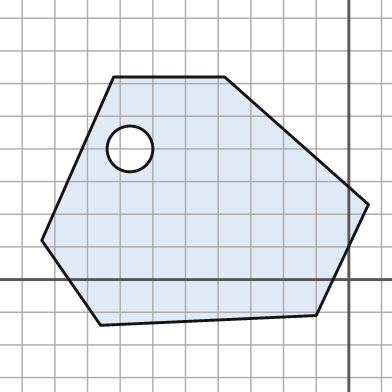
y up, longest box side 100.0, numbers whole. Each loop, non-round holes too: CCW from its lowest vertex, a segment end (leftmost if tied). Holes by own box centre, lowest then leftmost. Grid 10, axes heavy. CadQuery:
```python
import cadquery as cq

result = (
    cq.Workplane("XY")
    .moveTo(-76.0, -14.0)
    .lineTo(-10.0, -11.0)
    .lineTo(6.0, 23.0)
    .lineTo(-38.0, 62.0)
    .lineTo(-72.0, 62.0)
    .lineTo(-94.0, 12.0)
    .close()
    .moveTo(-67.0, 40.0)
    .circle(7.0)
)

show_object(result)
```